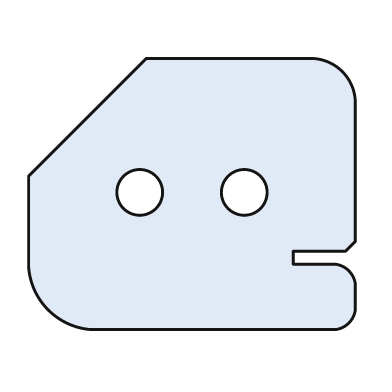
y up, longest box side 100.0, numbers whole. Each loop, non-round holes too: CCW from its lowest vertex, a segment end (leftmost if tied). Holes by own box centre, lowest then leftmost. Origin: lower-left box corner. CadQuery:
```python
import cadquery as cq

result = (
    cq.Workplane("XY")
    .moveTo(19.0, 0.0)
    .lineTo(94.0, 0.0)
    .threePointArc((98.0, 2.0), (100.0, 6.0))
    .lineTo(100.0, 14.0)
    .threePointArc((98.0, 18.0), (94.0, 20.0))
    .lineTo(81.0, 20.0)
    .lineTo(81.0, 24.0)
    .lineTo(97.0, 24.0)
    .lineTo(100.0, 27.0)
    .lineTo(100.0, 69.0)
    .threePointArc((96.0, 79.0), (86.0, 83.0))
    .lineTo(36.0, 83.0)
    .lineTo(0.0, 47.0)
    .lineTo(0.0, 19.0)
    .threePointArc((6.0, 6.0), (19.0, 0.0))
    .close()
    .moveTo(34.0, 42.0)
    .circle(7.0)
    .moveTo(66.0, 42.0)
    .circle(7.0)
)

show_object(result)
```